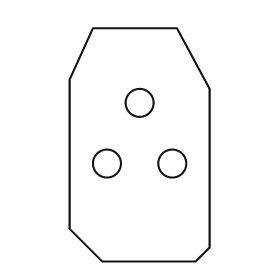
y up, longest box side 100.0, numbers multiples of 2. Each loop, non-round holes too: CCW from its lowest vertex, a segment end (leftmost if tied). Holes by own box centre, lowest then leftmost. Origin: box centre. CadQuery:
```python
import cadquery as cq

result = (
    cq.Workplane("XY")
    .moveTo(-16.0, -50.0)
    .lineTo(24.0, -50.0)
    .lineTo(30.0, -44.0)
    .lineTo(30.0, 24.0)
    .lineTo(16.0, 50.0)
    .lineTo(-20.0, 50.0)
    .lineTo(-30.0, 28.0)
    .lineTo(-30.0, -36.0)
    .close()
    .moveTo(-14.0, -8.0)
    .circle(6.0)
    .moveTo(14.0, -8.0)
    .circle(6.0)
    .moveTo(0.0, 18.0)
    .circle(6.0)
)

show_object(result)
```